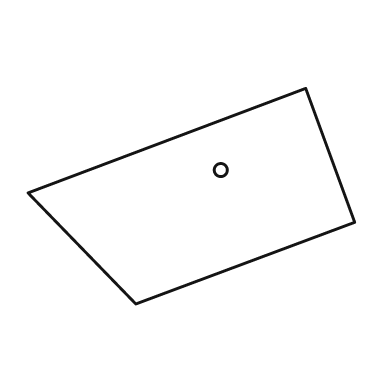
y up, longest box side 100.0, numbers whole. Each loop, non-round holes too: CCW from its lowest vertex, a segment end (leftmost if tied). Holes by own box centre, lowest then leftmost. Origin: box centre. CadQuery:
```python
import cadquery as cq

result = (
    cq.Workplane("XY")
    .moveTo(-17.0, -33.0)
    .lineTo(50.0, -8.0)
    .lineTo(35.0, 33.0)
    .lineTo(-50.0, 1.0)
    .close()
    .moveTo(9.0, 8.0)
    .circle(2.0)
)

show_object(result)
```